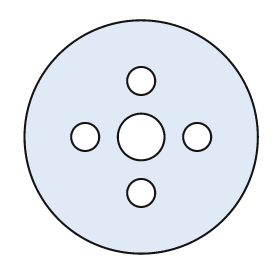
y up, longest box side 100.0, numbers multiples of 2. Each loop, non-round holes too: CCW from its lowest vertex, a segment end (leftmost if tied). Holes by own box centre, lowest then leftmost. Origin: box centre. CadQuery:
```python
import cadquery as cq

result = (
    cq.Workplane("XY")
    .moveTo(0.0, 0.0)
    .circle(50.0)
    .moveTo(0.0, -24.0)
    .circle(6.0)
    .moveTo(-24.0, 0.0)
    .circle(6.0)
    .moveTo(0.0, 0.0)
    .circle(10.0)
    .moveTo(24.0, 0.0)
    .circle(6.0)
    .moveTo(0.0, 24.0)
    .circle(6.0)
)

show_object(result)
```